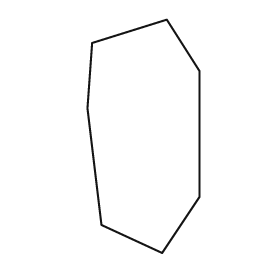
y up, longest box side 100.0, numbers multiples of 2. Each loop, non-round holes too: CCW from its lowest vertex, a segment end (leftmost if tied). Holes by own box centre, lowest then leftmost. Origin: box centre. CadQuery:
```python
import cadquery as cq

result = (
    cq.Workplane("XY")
    .moveTo(8.0, -50.0)
    .lineTo(24.0, -26.0)
    .lineTo(24.0, 28.0)
    .lineTo(10.0, 50.0)
    .lineTo(-22.0, 40.0)
    .lineTo(-24.0, 12.0)
    .lineTo(-18.0, -38.0)
    .close()
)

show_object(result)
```